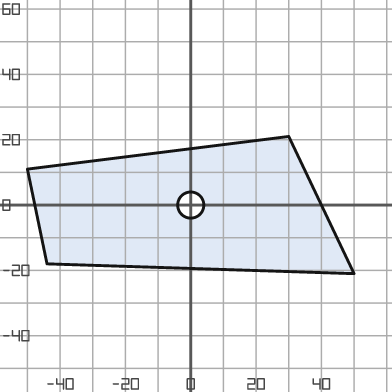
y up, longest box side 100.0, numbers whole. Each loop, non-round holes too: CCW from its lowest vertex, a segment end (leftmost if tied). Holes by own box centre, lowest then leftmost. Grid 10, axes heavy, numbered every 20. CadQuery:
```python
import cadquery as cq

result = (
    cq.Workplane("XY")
    .moveTo(50.0, -21.0)
    .lineTo(30.0, 21.0)
    .lineTo(-50.0, 11.0)
    .lineTo(-44.0, -18.0)
    .close()
    .moveTo(0.0, 0.0)
    .circle(4.0)
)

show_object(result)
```